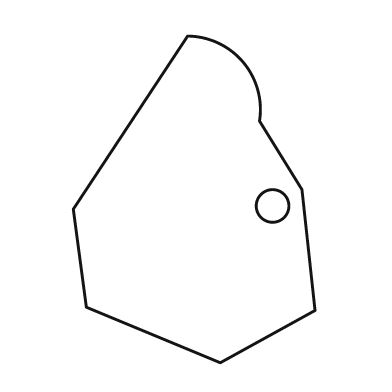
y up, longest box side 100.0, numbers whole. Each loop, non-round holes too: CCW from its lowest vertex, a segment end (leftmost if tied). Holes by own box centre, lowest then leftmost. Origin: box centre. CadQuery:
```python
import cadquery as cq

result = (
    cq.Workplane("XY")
    .moveTo(8.0, -50.0)
    .lineTo(37.0, -34.0)
    .lineTo(33.0, 3.0)
    .lineTo(20.0, 24.0)
    .threePointArc((15.0, 42.0), (-2.0, 50.0))
    .lineTo(-37.0, -3.0)
    .lineTo(-33.0, -33.0)
    .close()
    .moveTo(24.0, -2.0)
    .circle(5.0)
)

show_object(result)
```